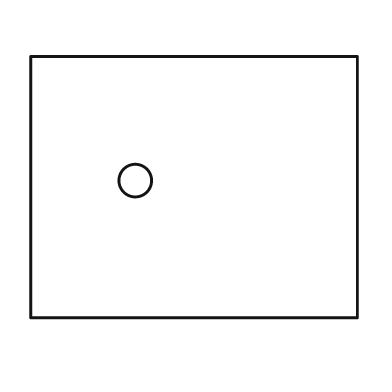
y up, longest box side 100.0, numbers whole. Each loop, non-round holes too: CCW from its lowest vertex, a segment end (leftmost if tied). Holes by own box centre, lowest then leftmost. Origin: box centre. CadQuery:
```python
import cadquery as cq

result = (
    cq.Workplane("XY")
    .moveTo(-50.0, -40.0)
    .lineTo(50.0, -40.0)
    .lineTo(50.0, 40.0)
    .lineTo(-50.0, 40.0)
    .close()
    .moveTo(-18.0, 2.0)
    .circle(5.0)
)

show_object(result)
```